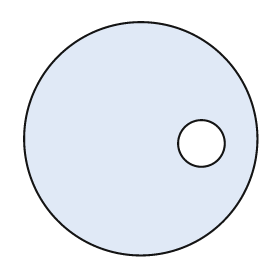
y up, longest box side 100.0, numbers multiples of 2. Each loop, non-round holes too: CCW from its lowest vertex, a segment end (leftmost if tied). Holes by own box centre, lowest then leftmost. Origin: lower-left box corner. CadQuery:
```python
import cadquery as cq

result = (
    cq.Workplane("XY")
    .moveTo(50.0, 50.0)
    .circle(50.0)
    .moveTo(76.0, 48.0)
    .circle(10.0)
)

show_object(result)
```